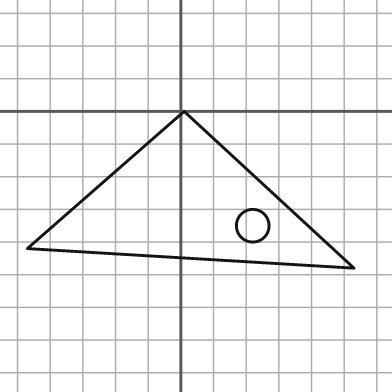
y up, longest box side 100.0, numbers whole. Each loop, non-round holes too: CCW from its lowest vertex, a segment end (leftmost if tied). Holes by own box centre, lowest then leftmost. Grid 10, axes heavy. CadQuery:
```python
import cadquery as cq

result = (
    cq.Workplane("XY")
    .moveTo(53.0, -48.0)
    .lineTo(1.0, 0.0)
    .lineTo(-47.0, -42.0)
    .close()
    .moveTo(22.0, -35.0)
    .circle(5.0)
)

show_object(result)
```